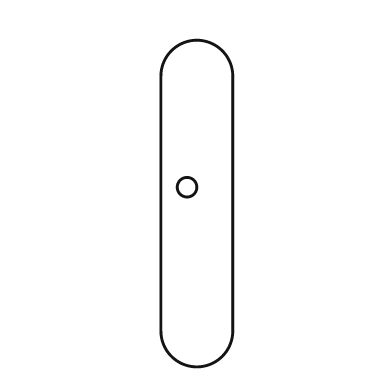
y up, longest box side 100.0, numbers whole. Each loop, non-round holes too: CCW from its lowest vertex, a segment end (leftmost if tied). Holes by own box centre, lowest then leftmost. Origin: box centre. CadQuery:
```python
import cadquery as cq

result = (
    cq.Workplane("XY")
    .moveTo(-11.0, -39.0)
    .threePointArc((0.0, -50.0), (11.0, -39.0))
    .lineTo(11.0, 39.0)
    .threePointArc((0.0, 50.0), (-11.0, 39.0))
    .close()
    .moveTo(-3.0, 5.0)
    .circle(3.0)
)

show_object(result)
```